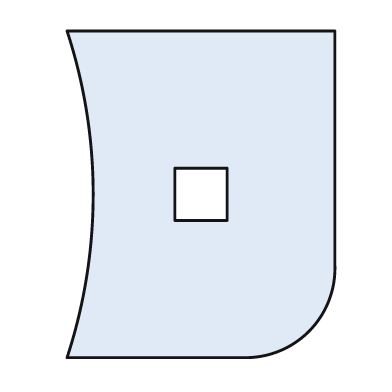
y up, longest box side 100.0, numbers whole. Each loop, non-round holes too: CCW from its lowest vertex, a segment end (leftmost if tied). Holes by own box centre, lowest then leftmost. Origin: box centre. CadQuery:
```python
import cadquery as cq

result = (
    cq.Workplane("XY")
    .moveTo(-41.0, -50.0)
    .lineTo(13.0, -50.0)
    .threePointArc((33.0, -42.0), (41.0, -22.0))
    .lineTo(41.0, 50.0)
    .lineTo(-41.0, 50.0)
    .threePointArc((-33.0, 0.0), (-41.0, -50.0))
    .close()
    .moveTo(-8.0, -8.0)
    .lineTo(8.0, -8.0)
    .lineTo(8.0, 8.0)
    .lineTo(-8.0, 8.0)
    .close()
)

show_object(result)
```